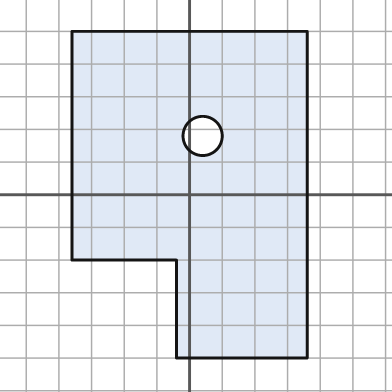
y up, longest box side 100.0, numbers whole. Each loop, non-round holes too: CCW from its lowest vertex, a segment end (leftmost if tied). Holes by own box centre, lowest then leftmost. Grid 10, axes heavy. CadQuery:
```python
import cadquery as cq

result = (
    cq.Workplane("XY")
    .moveTo(-4.0, -50.0)
    .lineTo(36.0, -50.0)
    .lineTo(36.0, 50.0)
    .lineTo(-36.0, 50.0)
    .lineTo(-36.0, -20.0)
    .lineTo(-4.0, -20.0)
    .close()
    .moveTo(4.0, 18.0)
    .circle(6.0)
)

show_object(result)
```